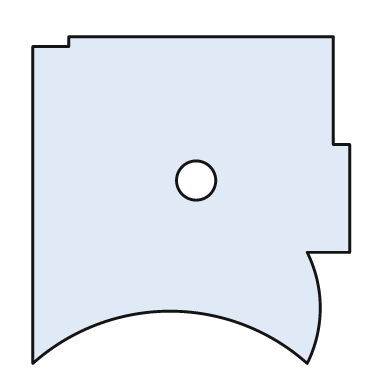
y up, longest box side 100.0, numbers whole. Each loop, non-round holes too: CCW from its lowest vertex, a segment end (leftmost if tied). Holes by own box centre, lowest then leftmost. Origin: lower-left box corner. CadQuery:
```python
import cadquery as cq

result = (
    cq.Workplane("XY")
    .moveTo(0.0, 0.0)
    .threePointArc((42.0, 16.0), (84.0, 0.0))
    .threePointArc((88.0, 17.0), (84.0, 34.0))
    .lineTo(97.0, 34.0)
    .lineTo(97.0, 67.0)
    .lineTo(92.0, 67.0)
    .lineTo(92.0, 100.0)
    .lineTo(11.0, 100.0)
    .lineTo(11.0, 97.0)
    .lineTo(0.0, 97.0)
    .close()
    .moveTo(50.0, 56.0)
    .circle(6.0)
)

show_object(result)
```